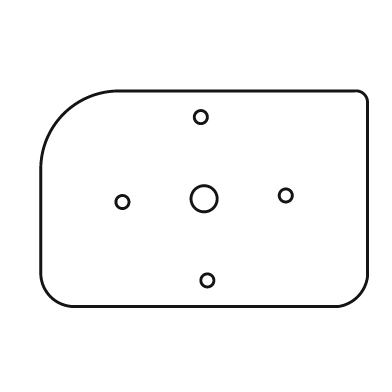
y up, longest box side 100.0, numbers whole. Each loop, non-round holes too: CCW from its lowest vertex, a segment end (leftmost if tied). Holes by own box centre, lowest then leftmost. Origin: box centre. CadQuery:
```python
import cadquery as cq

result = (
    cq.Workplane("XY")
    .moveTo(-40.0, -33.0)
    .lineTo(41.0, -33.0)
    .threePointArc((47.0, -30.0), (50.0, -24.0))
    .lineTo(50.0, 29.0)
    .threePointArc((49.0, 32.0), (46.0, 33.0))
    .lineTo(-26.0, 33.0)
    .threePointArc((-43.0, 26.0), (-50.0, 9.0))
    .lineTo(-50.0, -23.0)
    .threePointArc((-47.0, -30.0), (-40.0, -33.0))
    .close()
    .moveTo(1.0, -25.0)
    .circle(2.0)
    .moveTo(-25.0, -1.0)
    .circle(2.0)
    .moveTo(0.0, 0.0)
    .circle(4.0)
    .moveTo(25.0, 1.0)
    .circle(2.0)
    .moveTo(-1.0, 25.0)
    .circle(2.0)
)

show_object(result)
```